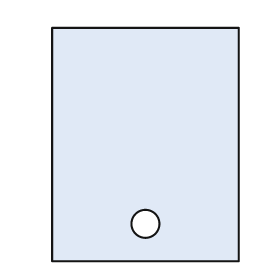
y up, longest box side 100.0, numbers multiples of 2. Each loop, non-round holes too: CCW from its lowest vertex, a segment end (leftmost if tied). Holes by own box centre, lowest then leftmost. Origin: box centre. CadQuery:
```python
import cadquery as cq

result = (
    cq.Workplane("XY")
    .moveTo(-40.0, -50.0)
    .lineTo(40.0, -50.0)
    .lineTo(40.0, 50.0)
    .lineTo(-40.0, 50.0)
    .close()
    .moveTo(0.0, -34.0)
    .circle(6.0)
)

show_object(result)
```